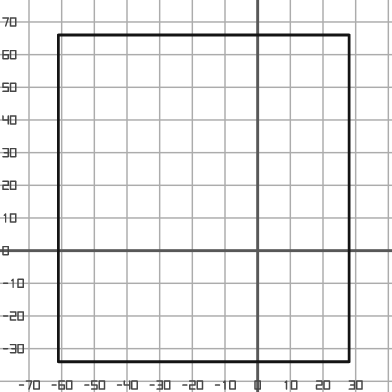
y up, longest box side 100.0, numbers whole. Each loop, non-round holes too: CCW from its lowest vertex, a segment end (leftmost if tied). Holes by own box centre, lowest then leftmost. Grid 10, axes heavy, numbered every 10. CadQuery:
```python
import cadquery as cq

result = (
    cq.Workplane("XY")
    .moveTo(-61.0, -34.0)
    .lineTo(28.0, -34.0)
    .lineTo(28.0, 66.0)
    .lineTo(-61.0, 66.0)
    .close()
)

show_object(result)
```